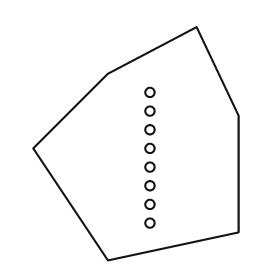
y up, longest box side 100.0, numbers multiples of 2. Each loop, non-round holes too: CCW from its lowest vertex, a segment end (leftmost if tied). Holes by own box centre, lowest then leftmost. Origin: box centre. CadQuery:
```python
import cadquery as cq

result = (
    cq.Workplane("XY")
    .moveTo(-12.0, -50.0)
    .lineTo(44.0, -38.0)
    .lineTo(44.0, 12.0)
    .lineTo(26.0, 50.0)
    .lineTo(-12.0, 30.0)
    .lineTo(-44.0, -2.0)
    .close()
    .moveTo(6.0, -34.0)
    .circle(2.0)
    .moveTo(6.0, -26.0)
    .circle(2.0)
    .moveTo(6.0, -18.0)
    .circle(2.0)
    .moveTo(6.0, -10.0)
    .circle(2.0)
    .moveTo(6.0, -2.0)
    .circle(2.0)
    .moveTo(6.0, 6.0)
    .circle(2.0)
    .moveTo(6.0, 14.0)
    .circle(2.0)
    .moveTo(6.0, 22.0)
    .circle(2.0)
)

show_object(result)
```